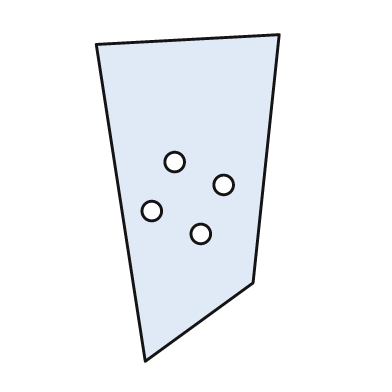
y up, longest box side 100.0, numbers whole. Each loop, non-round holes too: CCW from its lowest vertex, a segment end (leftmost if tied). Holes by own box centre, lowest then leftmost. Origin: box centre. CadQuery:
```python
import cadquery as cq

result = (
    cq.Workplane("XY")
    .moveTo(-13.0, -50.0)
    .lineTo(20.0, -26.0)
    .lineTo(28.0, 50.0)
    .lineTo(-28.0, 47.0)
    .close()
    .moveTo(4.0, -11.0)
    .circle(3.0)
    .moveTo(-11.0, -4.0)
    .circle(3.0)
    .moveTo(11.0, 4.0)
    .circle(3.0)
    .moveTo(-4.0, 11.0)
    .circle(3.0)
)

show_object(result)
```